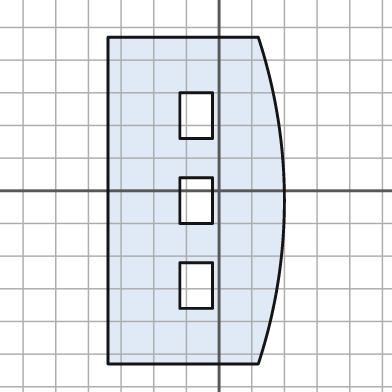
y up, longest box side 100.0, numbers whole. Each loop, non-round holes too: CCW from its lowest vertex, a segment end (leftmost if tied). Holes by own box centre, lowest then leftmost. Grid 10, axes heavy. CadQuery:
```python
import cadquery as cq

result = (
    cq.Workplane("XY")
    .moveTo(-34.0, -53.0)
    .lineTo(12.0, -53.0)
    .threePointArc((20.0, -3.0), (12.0, 47.0))
    .lineTo(-34.0, 47.0)
    .close()
    .moveTo(-12.0, -36.0)
    .lineTo(-2.0, -36.0)
    .lineTo(-2.0, -22.0)
    .lineTo(-12.0, -22.0)
    .close()
    .moveTo(-12.0, -10.0)
    .lineTo(-2.0, -10.0)
    .lineTo(-2.0, 4.0)
    .lineTo(-12.0, 4.0)
    .close()
    .moveTo(-12.0, 16.0)
    .lineTo(-2.0, 16.0)
    .lineTo(-2.0, 30.0)
    .lineTo(-12.0, 30.0)
    .close()
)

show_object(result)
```